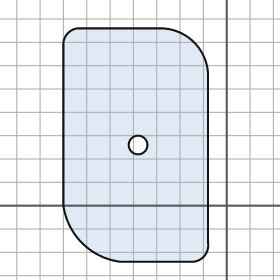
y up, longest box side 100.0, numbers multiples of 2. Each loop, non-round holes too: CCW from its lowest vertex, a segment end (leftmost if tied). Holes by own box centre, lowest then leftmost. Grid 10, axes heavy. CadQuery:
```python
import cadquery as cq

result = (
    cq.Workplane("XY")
    .moveTo(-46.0, -24.0)
    .lineTo(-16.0, -24.0)
    .threePointArc((-10.0, -22.0), (-8.0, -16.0))
    .lineTo(-8.0, 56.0)
    .threePointArc((-14.0, 70.0), (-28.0, 76.0))
    .lineTo(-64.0, 76.0)
    .threePointArc((-68.0, 74.0), (-70.0, 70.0))
    .lineTo(-70.0, 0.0)
    .threePointArc((-62.0, -16.0), (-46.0, -24.0))
    .close()
    .moveTo(-38.0, 26.0)
    .circle(4.0)
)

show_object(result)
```